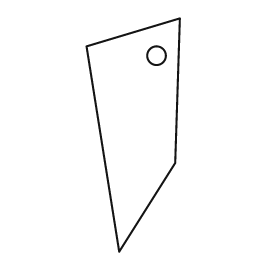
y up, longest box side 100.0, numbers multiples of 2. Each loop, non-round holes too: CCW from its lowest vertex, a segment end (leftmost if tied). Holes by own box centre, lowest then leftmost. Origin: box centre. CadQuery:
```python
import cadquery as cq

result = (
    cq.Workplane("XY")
    .moveTo(-6.0, -50.0)
    .lineTo(18.0, -12.0)
    .lineTo(20.0, 50.0)
    .lineTo(-20.0, 38.0)
    .close()
    .moveTo(10.0, 34.0)
    .circle(4.0)
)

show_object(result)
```